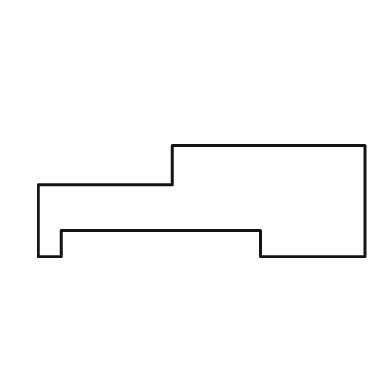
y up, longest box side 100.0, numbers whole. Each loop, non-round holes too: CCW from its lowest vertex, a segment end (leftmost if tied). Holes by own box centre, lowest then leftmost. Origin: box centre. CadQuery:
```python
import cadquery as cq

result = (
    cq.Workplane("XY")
    .moveTo(-50.0, -17.0)
    .lineTo(-43.0, -17.0)
    .lineTo(-43.0, -9.0)
    .lineTo(18.0, -9.0)
    .lineTo(18.0, -17.0)
    .lineTo(50.0, -17.0)
    .lineTo(50.0, 17.0)
    .lineTo(-9.0, 17.0)
    .lineTo(-9.0, 5.0)
    .lineTo(-50.0, 5.0)
    .close()
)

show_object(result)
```